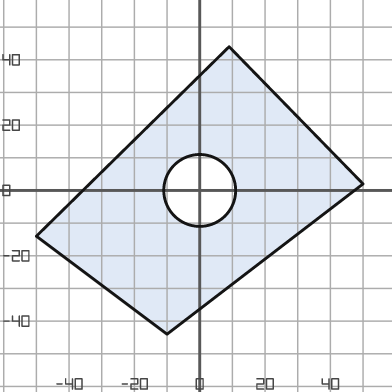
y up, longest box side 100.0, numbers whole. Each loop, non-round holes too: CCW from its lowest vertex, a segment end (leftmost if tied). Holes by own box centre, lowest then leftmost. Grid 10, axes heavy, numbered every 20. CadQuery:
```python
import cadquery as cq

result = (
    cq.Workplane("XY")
    .moveTo(-10.0, -44.0)
    .lineTo(50.0, 2.0)
    .lineTo(9.0, 44.0)
    .lineTo(-50.0, -14.0)
    .close()
    .moveTo(0.0, 0.0)
    .circle(11.0)
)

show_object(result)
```